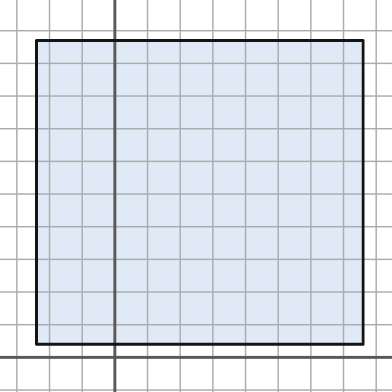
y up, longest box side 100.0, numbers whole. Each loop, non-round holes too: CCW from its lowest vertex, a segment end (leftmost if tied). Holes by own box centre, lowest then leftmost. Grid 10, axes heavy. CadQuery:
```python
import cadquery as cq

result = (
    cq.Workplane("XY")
    .moveTo(-24.0, 4.0)
    .lineTo(76.0, 4.0)
    .lineTo(76.0, 97.0)
    .lineTo(-24.0, 97.0)
    .close()
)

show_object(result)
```